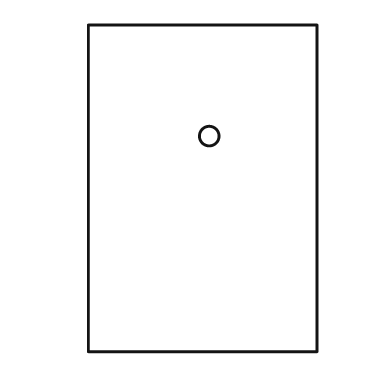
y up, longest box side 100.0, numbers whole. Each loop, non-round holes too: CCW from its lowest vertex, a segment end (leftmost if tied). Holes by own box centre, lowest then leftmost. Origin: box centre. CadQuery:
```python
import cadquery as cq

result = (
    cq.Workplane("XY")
    .moveTo(-35.0, -50.0)
    .lineTo(35.0, -50.0)
    .lineTo(35.0, 50.0)
    .lineTo(-35.0, 50.0)
    .close()
    .moveTo(2.0, 16.0)
    .circle(3.0)
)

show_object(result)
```